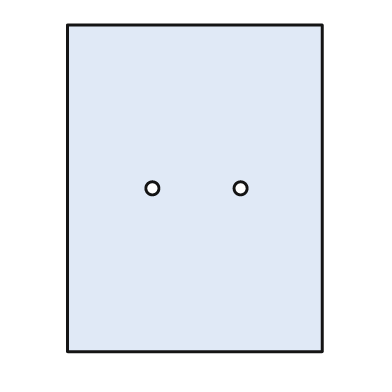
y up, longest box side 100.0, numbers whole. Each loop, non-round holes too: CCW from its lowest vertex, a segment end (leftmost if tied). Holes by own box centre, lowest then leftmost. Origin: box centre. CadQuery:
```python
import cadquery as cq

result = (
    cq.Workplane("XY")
    .moveTo(-39.0, -50.0)
    .lineTo(39.0, -50.0)
    .lineTo(39.0, 50.0)
    .lineTo(-39.0, 50.0)
    .close()
    .moveTo(-13.0, 0.0)
    .circle(2.0)
    .moveTo(14.0, 0.0)
    .circle(2.0)
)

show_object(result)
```